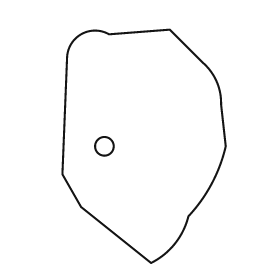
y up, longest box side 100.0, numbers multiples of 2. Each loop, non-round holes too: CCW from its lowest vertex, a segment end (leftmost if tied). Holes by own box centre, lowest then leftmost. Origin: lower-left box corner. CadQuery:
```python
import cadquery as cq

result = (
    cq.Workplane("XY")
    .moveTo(38.0, 0.0)
    .threePointArc((48.0, 8.0), (54.0, 20.0))
    .threePointArc((64.0, 34.0), (70.0, 50.0))
    .lineTo(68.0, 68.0)
    .threePointArc((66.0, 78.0), (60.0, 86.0))
    .lineTo(46.0, 100.0)
    .lineTo(20.0, 98.0)
    .threePointArc((8.0, 98.0), (2.0, 88.0))
    .lineTo(0.0, 38.0)
    .lineTo(8.0, 24.0)
    .close()
    .moveTo(18.0, 50.0)
    .circle(4.0)
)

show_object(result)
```